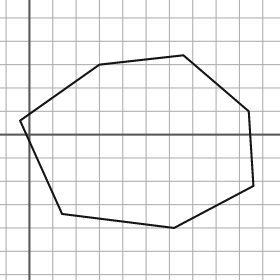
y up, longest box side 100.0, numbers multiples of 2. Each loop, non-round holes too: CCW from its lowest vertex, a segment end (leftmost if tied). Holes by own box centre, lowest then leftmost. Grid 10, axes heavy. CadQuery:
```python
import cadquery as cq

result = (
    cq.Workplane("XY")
    .moveTo(62.0, -40.0)
    .lineTo(96.0, -22.0)
    .lineTo(94.0, 10.0)
    .lineTo(66.0, 34.0)
    .lineTo(30.0, 30.0)
    .lineTo(-4.0, 6.0)
    .lineTo(14.0, -34.0)
    .close()
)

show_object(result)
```